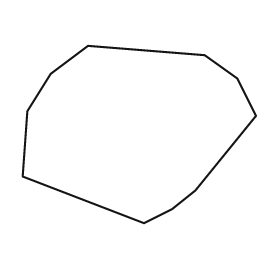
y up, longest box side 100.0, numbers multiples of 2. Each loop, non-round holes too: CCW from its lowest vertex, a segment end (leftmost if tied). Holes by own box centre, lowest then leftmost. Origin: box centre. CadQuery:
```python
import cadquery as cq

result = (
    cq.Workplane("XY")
    .moveTo(2.0, -38.0)
    .lineTo(14.0, -32.0)
    .lineTo(24.0, -24.0)
    .lineTo(50.0, 8.0)
    .lineTo(42.0, 24.0)
    .lineTo(28.0, 34.0)
    .lineTo(-22.0, 38.0)
    .lineTo(-38.0, 26.0)
    .lineTo(-48.0, 10.0)
    .lineTo(-50.0, -18.0)
    .close()
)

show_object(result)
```